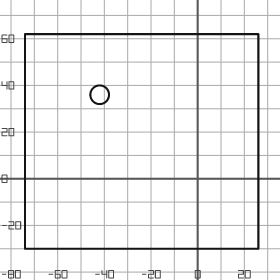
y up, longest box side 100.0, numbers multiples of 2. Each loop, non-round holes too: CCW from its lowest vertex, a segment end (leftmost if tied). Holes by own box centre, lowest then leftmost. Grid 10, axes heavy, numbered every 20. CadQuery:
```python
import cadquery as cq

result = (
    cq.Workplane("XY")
    .moveTo(-74.0, -30.0)
    .lineTo(26.0, -30.0)
    .lineTo(26.0, 62.0)
    .lineTo(-74.0, 62.0)
    .close()
    .moveTo(-42.0, 36.0)
    .circle(4.0)
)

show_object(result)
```